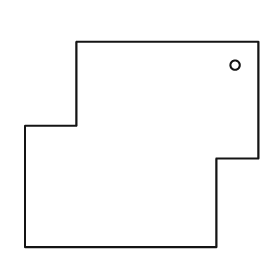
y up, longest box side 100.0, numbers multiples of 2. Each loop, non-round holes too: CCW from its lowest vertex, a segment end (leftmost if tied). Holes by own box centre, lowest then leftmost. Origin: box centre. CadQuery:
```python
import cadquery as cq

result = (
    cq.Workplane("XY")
    .moveTo(-50.0, -44.0)
    .lineTo(32.0, -44.0)
    .lineTo(32.0, -6.0)
    .lineTo(50.0, -6.0)
    .lineTo(50.0, 44.0)
    .lineTo(-28.0, 44.0)
    .lineTo(-28.0, 8.0)
    .lineTo(-50.0, 8.0)
    .close()
    .moveTo(40.0, 34.0)
    .circle(2.0)
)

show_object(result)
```